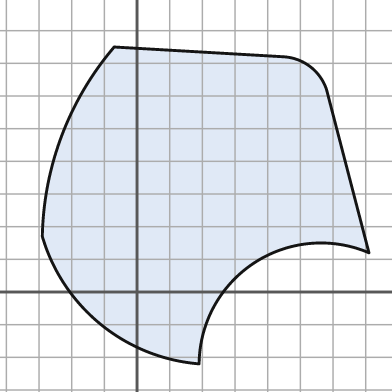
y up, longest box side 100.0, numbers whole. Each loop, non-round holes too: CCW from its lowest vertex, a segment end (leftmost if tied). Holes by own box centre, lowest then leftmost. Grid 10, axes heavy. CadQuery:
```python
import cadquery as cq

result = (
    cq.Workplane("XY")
    .moveTo(19.0, -22.0)
    .threePointArc((36.0, 9.0), (71.0, 12.0))
    .lineTo(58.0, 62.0)
    .threePointArc((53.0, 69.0), (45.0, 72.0))
    .lineTo(-7.0, 75.0)
    .threePointArc((-23.0, 48.0), (-29.0, 17.0))
    .threePointArc((-11.0, -10.0), (19.0, -22.0))
    .close()
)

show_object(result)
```